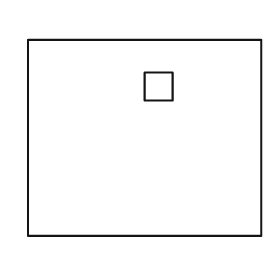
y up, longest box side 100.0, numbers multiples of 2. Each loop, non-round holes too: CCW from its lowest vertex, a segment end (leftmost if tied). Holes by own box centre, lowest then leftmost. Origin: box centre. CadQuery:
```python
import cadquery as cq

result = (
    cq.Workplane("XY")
    .moveTo(-50.0, -42.0)
    .lineTo(50.0, -42.0)
    .lineTo(50.0, 42.0)
    .lineTo(-50.0, 42.0)
    .close()
    .moveTo(0.0, 16.0)
    .lineTo(12.0, 16.0)
    .lineTo(12.0, 28.0)
    .lineTo(0.0, 28.0)
    .close()
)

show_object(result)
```